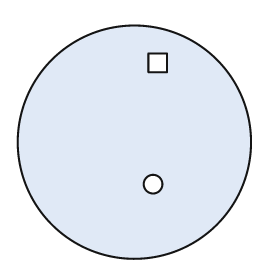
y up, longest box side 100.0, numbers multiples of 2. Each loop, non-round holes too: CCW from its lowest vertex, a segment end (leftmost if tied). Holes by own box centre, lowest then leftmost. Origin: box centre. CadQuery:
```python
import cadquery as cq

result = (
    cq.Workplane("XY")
    .moveTo(0.0, 0.0)
    .circle(50.0)
    .moveTo(8.0, -18.0)
    .circle(4.0)
    .moveTo(6.0, 30.0)
    .lineTo(14.0, 30.0)
    .lineTo(14.0, 38.0)
    .lineTo(6.0, 38.0)
    .close()
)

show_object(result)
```